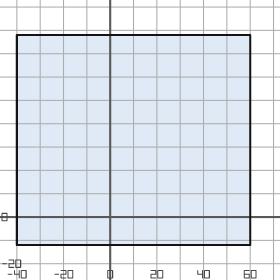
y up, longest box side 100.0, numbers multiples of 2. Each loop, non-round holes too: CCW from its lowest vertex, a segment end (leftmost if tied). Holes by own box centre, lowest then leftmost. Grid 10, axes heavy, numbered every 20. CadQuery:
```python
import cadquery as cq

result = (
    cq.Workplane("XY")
    .moveTo(-40.0, -12.0)
    .lineTo(60.0, -12.0)
    .lineTo(60.0, 78.0)
    .lineTo(-40.0, 78.0)
    .close()
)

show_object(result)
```